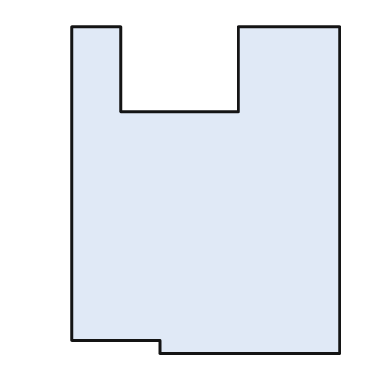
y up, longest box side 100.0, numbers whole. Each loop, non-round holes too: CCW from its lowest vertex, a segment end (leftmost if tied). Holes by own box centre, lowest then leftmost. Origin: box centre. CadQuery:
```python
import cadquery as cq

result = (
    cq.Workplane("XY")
    .moveTo(-14.0, -50.0)
    .lineTo(41.0, -50.0)
    .lineTo(41.0, 50.0)
    .lineTo(10.0, 50.0)
    .lineTo(10.0, 24.0)
    .lineTo(-26.0, 24.0)
    .lineTo(-26.0, 50.0)
    .lineTo(-41.0, 50.0)
    .lineTo(-41.0, -46.0)
    .lineTo(-14.0, -46.0)
    .close()
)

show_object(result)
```